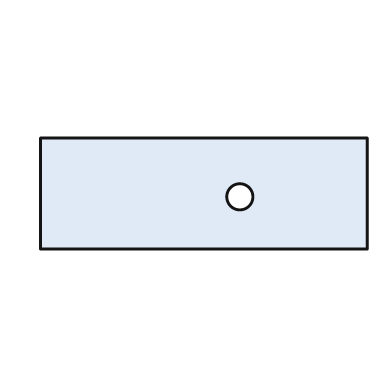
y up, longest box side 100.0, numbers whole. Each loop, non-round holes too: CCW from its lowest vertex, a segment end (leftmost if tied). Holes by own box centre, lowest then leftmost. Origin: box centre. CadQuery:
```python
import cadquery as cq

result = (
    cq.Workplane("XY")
    .moveTo(-50.0, -17.0)
    .lineTo(50.0, -17.0)
    .lineTo(50.0, 17.0)
    .lineTo(-50.0, 17.0)
    .close()
    .moveTo(11.0, -1.0)
    .circle(4.0)
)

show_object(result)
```